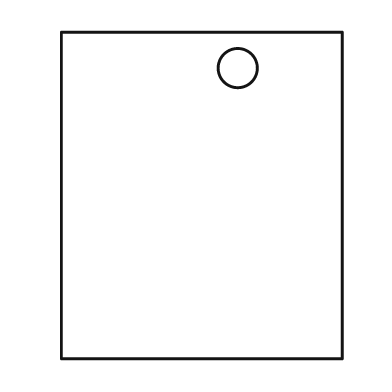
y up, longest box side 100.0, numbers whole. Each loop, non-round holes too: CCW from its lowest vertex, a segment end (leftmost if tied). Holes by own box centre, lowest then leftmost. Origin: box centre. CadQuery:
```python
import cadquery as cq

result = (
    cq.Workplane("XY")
    .moveTo(-43.0, -50.0)
    .lineTo(43.0, -50.0)
    .lineTo(43.0, 50.0)
    .lineTo(-43.0, 50.0)
    .close()
    .moveTo(11.0, 39.0)
    .circle(6.0)
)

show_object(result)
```